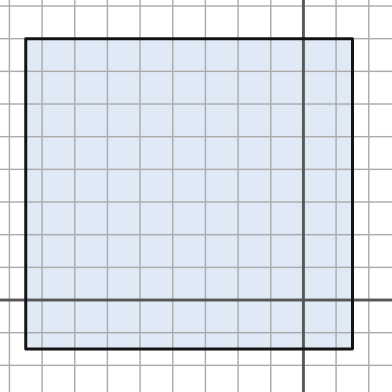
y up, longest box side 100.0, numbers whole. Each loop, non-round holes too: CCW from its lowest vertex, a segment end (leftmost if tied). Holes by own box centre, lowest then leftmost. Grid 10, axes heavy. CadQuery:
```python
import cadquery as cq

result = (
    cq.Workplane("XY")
    .moveTo(-85.0, -15.0)
    .lineTo(15.0, -15.0)
    .lineTo(15.0, 80.0)
    .lineTo(-85.0, 80.0)
    .close()
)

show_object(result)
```